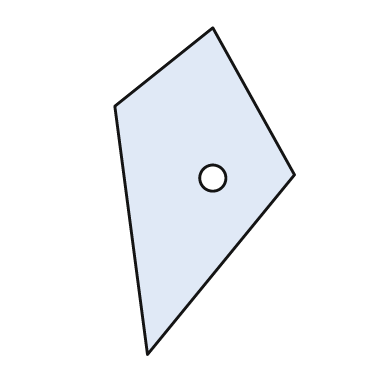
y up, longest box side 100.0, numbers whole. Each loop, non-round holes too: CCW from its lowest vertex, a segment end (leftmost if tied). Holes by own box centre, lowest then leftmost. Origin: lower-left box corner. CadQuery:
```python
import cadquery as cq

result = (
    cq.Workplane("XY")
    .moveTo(10.0, 0.0)
    .lineTo(55.0, 55.0)
    .lineTo(30.0, 100.0)
    .lineTo(0.0, 76.0)
    .close()
    .moveTo(30.0, 54.0)
    .circle(4.0)
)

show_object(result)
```